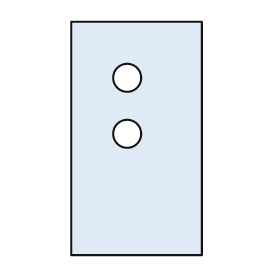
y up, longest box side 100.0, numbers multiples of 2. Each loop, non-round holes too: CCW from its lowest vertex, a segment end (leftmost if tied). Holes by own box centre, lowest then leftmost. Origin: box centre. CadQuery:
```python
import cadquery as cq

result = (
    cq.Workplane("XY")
    .moveTo(-28.0, -50.0)
    .lineTo(28.0, -50.0)
    .lineTo(28.0, 50.0)
    .lineTo(-28.0, 50.0)
    .close()
    .moveTo(-4.0, 2.0)
    .circle(6.0)
    .moveTo(-4.0, 26.0)
    .circle(6.0)
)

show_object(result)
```